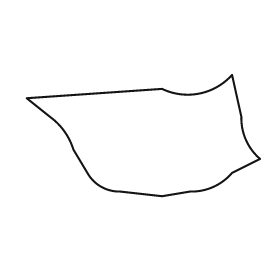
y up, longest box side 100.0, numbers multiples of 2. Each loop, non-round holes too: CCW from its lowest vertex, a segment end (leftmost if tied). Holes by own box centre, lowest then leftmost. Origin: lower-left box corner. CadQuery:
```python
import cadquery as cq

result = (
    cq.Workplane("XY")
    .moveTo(58.0, 0.0)
    .lineTo(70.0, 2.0)
    .threePointArc((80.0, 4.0), (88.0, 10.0))
    .lineTo(100.0, 16.0)
    .threePointArc((94.0, 24.0), (92.0, 34.0))
    .lineTo(88.0, 52.0)
    .threePointArc((74.0, 44.0), (58.0, 46.0))
    .lineTo(0.0, 42.0)
    .lineTo(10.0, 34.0)
    .threePointArc((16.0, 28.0), (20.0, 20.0))
    .lineTo(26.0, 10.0)
    .threePointArc((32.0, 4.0), (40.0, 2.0))
    .close()
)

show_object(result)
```